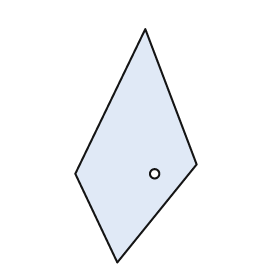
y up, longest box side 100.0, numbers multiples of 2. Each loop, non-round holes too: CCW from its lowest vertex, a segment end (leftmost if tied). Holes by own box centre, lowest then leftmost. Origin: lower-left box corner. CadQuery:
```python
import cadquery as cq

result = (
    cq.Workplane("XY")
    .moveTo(18.0, 0.0)
    .lineTo(52.0, 42.0)
    .lineTo(30.0, 100.0)
    .lineTo(0.0, 38.0)
    .close()
    .moveTo(34.0, 38.0)
    .circle(2.0)
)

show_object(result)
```